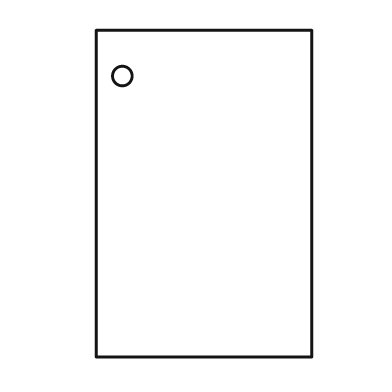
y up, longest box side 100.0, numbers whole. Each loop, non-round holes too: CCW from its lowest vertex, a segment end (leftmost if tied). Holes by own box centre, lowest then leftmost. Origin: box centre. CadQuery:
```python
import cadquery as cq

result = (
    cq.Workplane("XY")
    .moveTo(-33.0, -50.0)
    .lineTo(33.0, -50.0)
    .lineTo(33.0, 50.0)
    .lineTo(-33.0, 50.0)
    .close()
    .moveTo(-25.0, 36.0)
    .circle(3.0)
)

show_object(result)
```